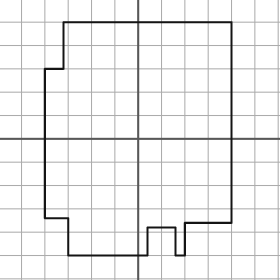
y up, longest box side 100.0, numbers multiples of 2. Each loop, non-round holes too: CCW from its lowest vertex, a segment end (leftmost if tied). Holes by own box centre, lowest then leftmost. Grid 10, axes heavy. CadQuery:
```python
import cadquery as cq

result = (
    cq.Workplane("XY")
    .moveTo(-30.0, -50.0)
    .lineTo(4.0, -50.0)
    .lineTo(4.0, -38.0)
    .lineTo(16.0, -38.0)
    .lineTo(16.0, -50.0)
    .lineTo(20.0, -50.0)
    .lineTo(20.0, -36.0)
    .lineTo(40.0, -36.0)
    .lineTo(40.0, 50.0)
    .lineTo(-32.0, 50.0)
    .lineTo(-32.0, 30.0)
    .lineTo(-40.0, 30.0)
    .lineTo(-40.0, -34.0)
    .lineTo(-30.0, -34.0)
    .close()
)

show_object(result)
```